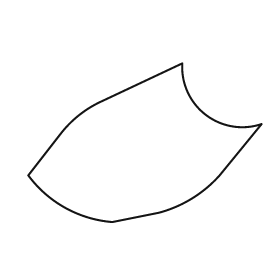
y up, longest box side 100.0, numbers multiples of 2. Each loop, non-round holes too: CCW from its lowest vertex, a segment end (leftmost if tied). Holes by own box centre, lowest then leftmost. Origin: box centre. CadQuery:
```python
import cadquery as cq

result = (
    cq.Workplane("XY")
    .moveTo(-14.0, -34.0)
    .lineTo(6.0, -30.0)
    .threePointArc((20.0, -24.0), (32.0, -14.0))
    .lineTo(50.0, 8.0)
    .threePointArc((26.0, 12.0), (16.0, 34.0))
    .lineTo(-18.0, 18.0)
    .threePointArc((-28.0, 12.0), (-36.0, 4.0))
    .lineTo(-50.0, -14.0)
    .threePointArc((-34.0, -28.0), (-14.0, -34.0))
    .close()
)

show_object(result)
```